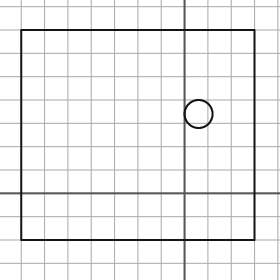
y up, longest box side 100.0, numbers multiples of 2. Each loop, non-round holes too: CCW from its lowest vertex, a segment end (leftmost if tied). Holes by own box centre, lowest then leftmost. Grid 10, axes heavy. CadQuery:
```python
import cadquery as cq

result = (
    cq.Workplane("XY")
    .moveTo(-70.0, -20.0)
    .lineTo(30.0, -20.0)
    .lineTo(30.0, 70.0)
    .lineTo(-70.0, 70.0)
    .close()
    .moveTo(6.0, 34.0)
    .circle(6.0)
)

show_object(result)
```